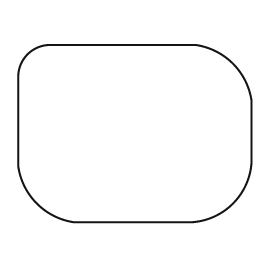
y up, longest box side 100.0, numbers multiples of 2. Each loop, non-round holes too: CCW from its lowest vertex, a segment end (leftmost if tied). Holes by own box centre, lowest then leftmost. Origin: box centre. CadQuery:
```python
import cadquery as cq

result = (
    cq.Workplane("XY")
    .moveTo(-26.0, -38.0)
    .lineTo(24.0, -38.0)
    .threePointArc((42.0, -30.0), (50.0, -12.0))
    .lineTo(50.0, 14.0)
    .threePointArc((42.0, 30.0), (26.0, 38.0))
    .lineTo(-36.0, 38.0)
    .threePointArc((-46.0, 34.0), (-50.0, 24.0))
    .lineTo(-50.0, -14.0)
    .threePointArc((-42.0, -30.0), (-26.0, -38.0))
    .close()
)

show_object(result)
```